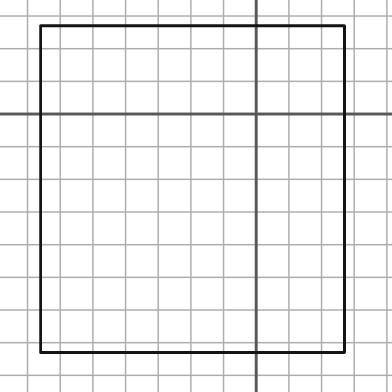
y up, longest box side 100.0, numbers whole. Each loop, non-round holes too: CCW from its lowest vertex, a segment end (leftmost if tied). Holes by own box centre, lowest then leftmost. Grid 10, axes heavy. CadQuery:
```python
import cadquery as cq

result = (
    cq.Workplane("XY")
    .moveTo(-66.0, -73.0)
    .lineTo(27.0, -73.0)
    .lineTo(27.0, 27.0)
    .lineTo(-66.0, 27.0)
    .close()
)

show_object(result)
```